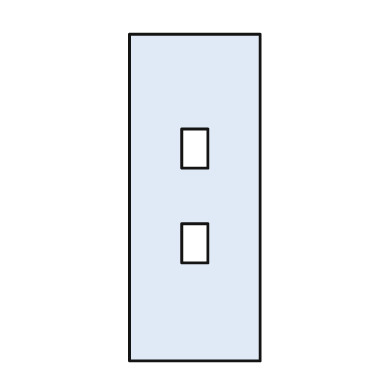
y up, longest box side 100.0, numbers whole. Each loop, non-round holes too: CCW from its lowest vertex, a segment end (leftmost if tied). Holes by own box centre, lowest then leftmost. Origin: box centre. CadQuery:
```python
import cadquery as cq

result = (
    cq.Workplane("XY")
    .moveTo(-20.0, -50.0)
    .lineTo(20.0, -50.0)
    .lineTo(20.0, 50.0)
    .lineTo(-20.0, 50.0)
    .close()
    .moveTo(-4.0, -20.0)
    .lineTo(4.0, -20.0)
    .lineTo(4.0, -8.0)
    .lineTo(-4.0, -8.0)
    .close()
    .moveTo(-4.0, 9.0)
    .lineTo(4.0, 9.0)
    .lineTo(4.0, 21.0)
    .lineTo(-4.0, 21.0)
    .close()
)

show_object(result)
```